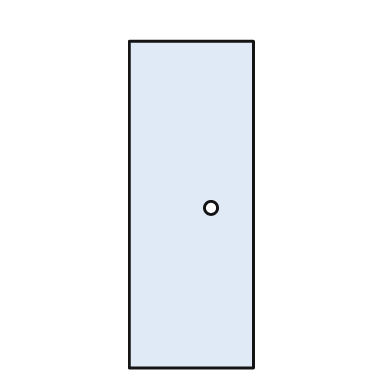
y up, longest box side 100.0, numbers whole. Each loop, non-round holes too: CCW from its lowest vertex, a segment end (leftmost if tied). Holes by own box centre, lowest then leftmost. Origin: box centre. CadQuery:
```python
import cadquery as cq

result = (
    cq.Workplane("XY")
    .moveTo(-19.0, -50.0)
    .lineTo(19.0, -50.0)
    .lineTo(19.0, 50.0)
    .lineTo(-19.0, 50.0)
    .close()
    .moveTo(6.0, -1.0)
    .circle(2.0)
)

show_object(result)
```